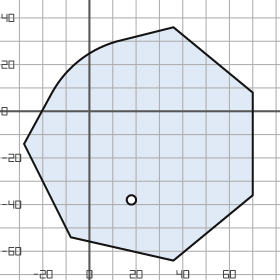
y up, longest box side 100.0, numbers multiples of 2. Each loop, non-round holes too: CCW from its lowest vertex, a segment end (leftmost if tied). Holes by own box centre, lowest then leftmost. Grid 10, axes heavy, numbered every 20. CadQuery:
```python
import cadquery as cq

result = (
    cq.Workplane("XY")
    .moveTo(36.0, -64.0)
    .lineTo(70.0, -36.0)
    .lineTo(70.0, 8.0)
    .lineTo(36.0, 36.0)
    .lineTo(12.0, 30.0)
    .threePointArc((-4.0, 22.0), (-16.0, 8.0))
    .lineTo(-28.0, -14.0)
    .lineTo(-8.0, -54.0)
    .close()
    .moveTo(18.0, -38.0)
    .circle(2.0)
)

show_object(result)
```